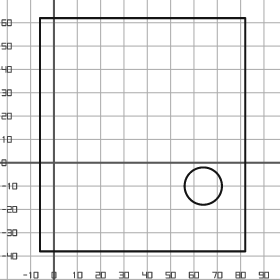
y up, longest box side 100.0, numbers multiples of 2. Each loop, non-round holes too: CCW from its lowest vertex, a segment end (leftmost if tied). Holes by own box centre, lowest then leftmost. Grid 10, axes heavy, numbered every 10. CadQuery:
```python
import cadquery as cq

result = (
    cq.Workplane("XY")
    .moveTo(-6.0, -38.0)
    .lineTo(82.0, -38.0)
    .lineTo(82.0, 62.0)
    .lineTo(-6.0, 62.0)
    .close()
    .moveTo(64.0, -10.0)
    .circle(8.0)
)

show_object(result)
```